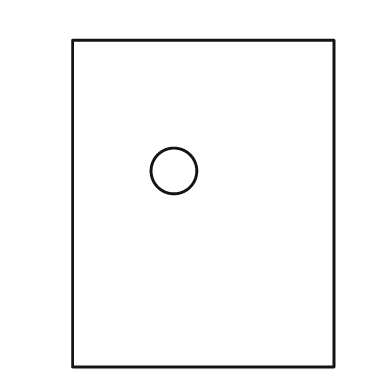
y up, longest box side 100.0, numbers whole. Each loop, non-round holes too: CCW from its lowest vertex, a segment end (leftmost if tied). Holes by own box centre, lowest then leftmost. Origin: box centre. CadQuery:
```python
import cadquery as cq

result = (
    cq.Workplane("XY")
    .moveTo(-40.0, -50.0)
    .lineTo(40.0, -50.0)
    .lineTo(40.0, 50.0)
    .lineTo(-40.0, 50.0)
    .close()
    .moveTo(-9.0, 10.0)
    .circle(7.0)
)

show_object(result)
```